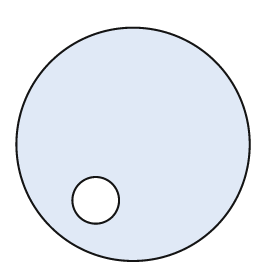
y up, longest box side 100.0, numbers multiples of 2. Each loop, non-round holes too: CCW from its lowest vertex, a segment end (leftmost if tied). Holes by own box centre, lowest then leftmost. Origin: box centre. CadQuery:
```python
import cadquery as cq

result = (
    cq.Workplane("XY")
    .moveTo(0.0, 0.0)
    .circle(50.0)
    .moveTo(-16.0, -24.0)
    .circle(10.0)
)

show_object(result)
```